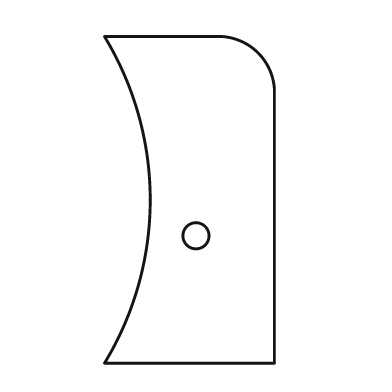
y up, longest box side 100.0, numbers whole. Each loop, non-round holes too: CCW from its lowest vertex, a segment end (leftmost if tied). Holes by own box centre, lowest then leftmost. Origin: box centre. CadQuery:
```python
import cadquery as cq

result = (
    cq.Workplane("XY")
    .moveTo(-26.0, -50.0)
    .lineTo(26.0, -50.0)
    .lineTo(26.0, 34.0)
    .threePointArc((21.0, 45.0), (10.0, 50.0))
    .lineTo(-26.0, 50.0)
    .threePointArc((-12.0, 0.0), (-26.0, -50.0))
    .close()
    .moveTo(2.0, -11.0)
    .circle(4.0)
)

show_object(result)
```